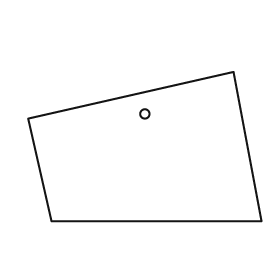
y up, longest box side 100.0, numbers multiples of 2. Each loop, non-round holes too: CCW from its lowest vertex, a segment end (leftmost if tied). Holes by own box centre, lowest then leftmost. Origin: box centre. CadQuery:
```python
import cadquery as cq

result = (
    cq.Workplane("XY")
    .moveTo(-40.0, -32.0)
    .lineTo(50.0, -32.0)
    .lineTo(38.0, 32.0)
    .lineTo(-50.0, 12.0)
    .close()
    .moveTo(0.0, 14.0)
    .circle(2.0)
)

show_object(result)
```